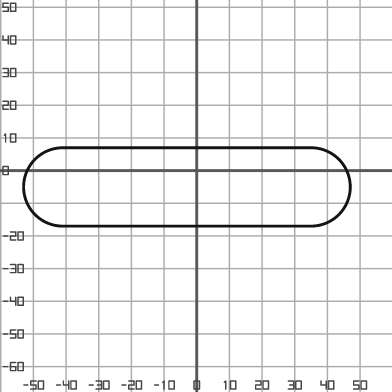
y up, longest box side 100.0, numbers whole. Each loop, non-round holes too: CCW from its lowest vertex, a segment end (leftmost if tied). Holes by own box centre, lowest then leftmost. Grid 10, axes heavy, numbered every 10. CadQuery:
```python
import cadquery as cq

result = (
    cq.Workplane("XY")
    .moveTo(-41.0, -17.0)
    .lineTo(35.0, -17.0)
    .threePointArc((47.0, -5.0), (35.0, 7.0))
    .lineTo(-41.0, 7.0)
    .threePointArc((-53.0, -5.0), (-41.0, -17.0))
    .close()
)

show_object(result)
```